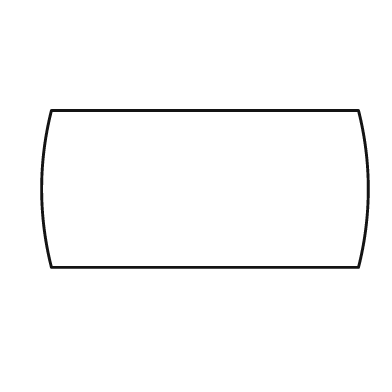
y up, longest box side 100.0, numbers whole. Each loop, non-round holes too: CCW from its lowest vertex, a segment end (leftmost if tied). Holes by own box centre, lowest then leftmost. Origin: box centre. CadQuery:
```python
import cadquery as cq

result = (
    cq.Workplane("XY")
    .moveTo(-47.0, -24.0)
    .lineTo(47.0, -24.0)
    .threePointArc((50.0, 0.0), (47.0, 24.0))
    .lineTo(-47.0, 24.0)
    .threePointArc((-50.0, 0.0), (-47.0, -24.0))
    .close()
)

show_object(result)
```